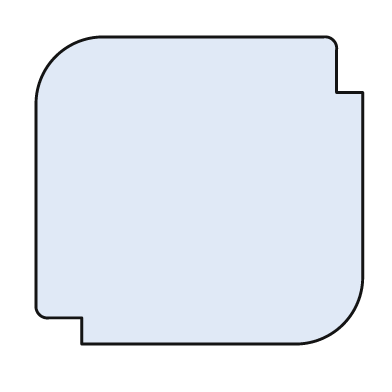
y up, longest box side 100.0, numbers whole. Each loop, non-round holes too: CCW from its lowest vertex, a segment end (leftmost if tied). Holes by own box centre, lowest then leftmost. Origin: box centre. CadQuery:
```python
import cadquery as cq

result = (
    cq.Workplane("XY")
    .moveTo(-36.0, -47.0)
    .lineTo(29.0, -47.0)
    .threePointArc((44.0, -41.0), (50.0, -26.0))
    .lineTo(50.0, 30.0)
    .lineTo(42.0, 30.0)
    .lineTo(42.0, 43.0)
    .threePointArc((41.0, 46.0), (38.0, 47.0))
    .lineTo(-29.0, 47.0)
    .threePointArc((-44.0, 41.0), (-50.0, 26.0))
    .lineTo(-50.0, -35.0)
    .threePointArc((-49.0, -38.0), (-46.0, -39.0))
    .lineTo(-36.0, -39.0)
    .close()
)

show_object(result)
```